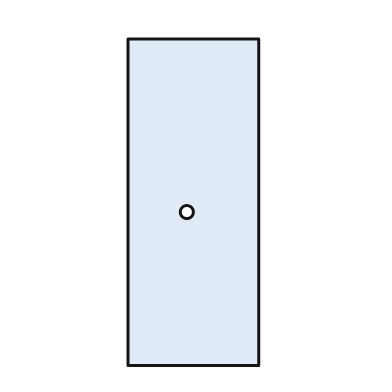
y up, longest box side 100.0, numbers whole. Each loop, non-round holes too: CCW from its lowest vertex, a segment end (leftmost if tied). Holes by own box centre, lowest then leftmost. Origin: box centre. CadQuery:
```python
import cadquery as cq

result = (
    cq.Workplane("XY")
    .moveTo(-20.0, -50.0)
    .lineTo(20.0, -50.0)
    .lineTo(20.0, 50.0)
    .lineTo(-20.0, 50.0)
    .close()
    .moveTo(-2.0, -3.0)
    .circle(2.0)
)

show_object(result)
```